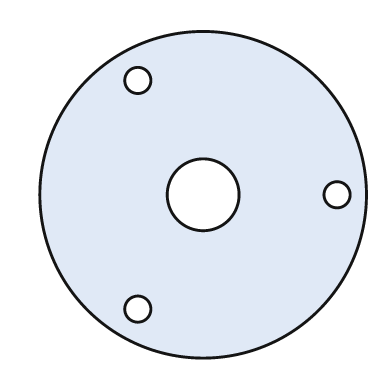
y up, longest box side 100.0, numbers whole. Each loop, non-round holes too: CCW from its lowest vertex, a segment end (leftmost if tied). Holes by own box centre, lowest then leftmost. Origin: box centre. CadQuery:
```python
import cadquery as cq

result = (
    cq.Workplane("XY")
    .moveTo(0.0, 0.0)
    .circle(50.0)
    .moveTo(-20.0, -35.0)
    .circle(4.0)
    .moveTo(0.0, 0.0)
    .circle(11.0)
    .moveTo(41.0, 0.0)
    .circle(4.0)
    .moveTo(-20.0, 35.0)
    .circle(4.0)
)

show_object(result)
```